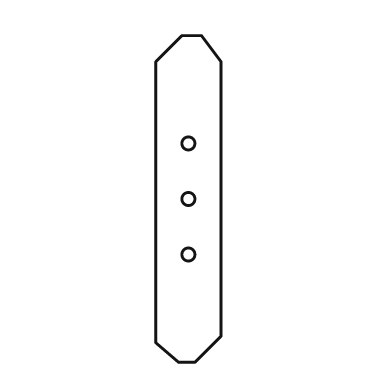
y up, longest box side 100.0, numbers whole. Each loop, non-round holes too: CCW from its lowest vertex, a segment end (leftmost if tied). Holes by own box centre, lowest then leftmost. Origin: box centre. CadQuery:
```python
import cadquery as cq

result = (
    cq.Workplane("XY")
    .moveTo(-3.0, -50.0)
    .lineTo(2.0, -50.0)
    .lineTo(10.0, -42.0)
    .lineTo(10.0, 42.0)
    .lineTo(4.0, 50.0)
    .lineTo(-2.0, 50.0)
    .lineTo(-10.0, 42.0)
    .lineTo(-10.0, -44.0)
    .close()
    .moveTo(0.0, -17.0)
    .circle(2.0)
    .moveTo(0.0, 0.0)
    .circle(2.0)
    .moveTo(0.0, 17.0)
    .circle(2.0)
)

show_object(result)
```